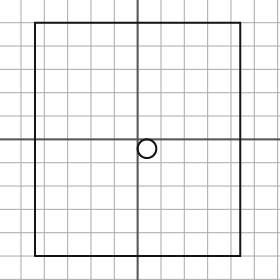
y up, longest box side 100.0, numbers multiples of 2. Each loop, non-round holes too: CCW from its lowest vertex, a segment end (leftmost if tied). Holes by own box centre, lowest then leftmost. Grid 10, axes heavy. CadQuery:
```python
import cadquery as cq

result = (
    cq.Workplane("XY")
    .moveTo(-44.0, -50.0)
    .lineTo(44.0, -50.0)
    .lineTo(44.0, 50.0)
    .lineTo(-44.0, 50.0)
    .close()
    .moveTo(4.0, -4.0)
    .circle(4.0)
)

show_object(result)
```